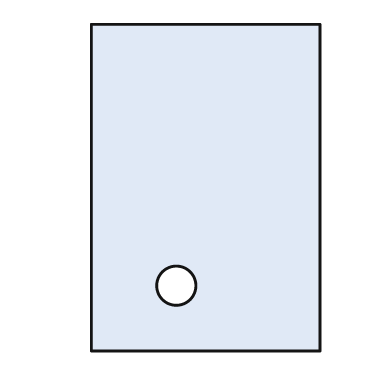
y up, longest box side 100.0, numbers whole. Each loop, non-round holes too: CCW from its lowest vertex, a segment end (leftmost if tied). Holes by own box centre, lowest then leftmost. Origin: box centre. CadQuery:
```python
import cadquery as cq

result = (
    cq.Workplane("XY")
    .moveTo(-35.0, -50.0)
    .lineTo(35.0, -50.0)
    .lineTo(35.0, 50.0)
    .lineTo(-35.0, 50.0)
    .close()
    .moveTo(-9.0, -30.0)
    .circle(6.0)
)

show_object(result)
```